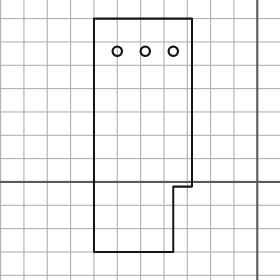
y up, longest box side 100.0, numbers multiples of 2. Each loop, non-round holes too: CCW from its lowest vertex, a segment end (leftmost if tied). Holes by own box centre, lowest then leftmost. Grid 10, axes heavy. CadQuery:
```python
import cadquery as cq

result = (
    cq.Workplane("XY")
    .moveTo(-70.0, -30.0)
    .lineTo(-36.0, -30.0)
    .lineTo(-36.0, -2.0)
    .lineTo(-28.0, -2.0)
    .lineTo(-28.0, 70.0)
    .lineTo(-70.0, 70.0)
    .close()
    .moveTo(-60.0, 56.0)
    .circle(2.0)
    .moveTo(-48.0, 56.0)
    .circle(2.0)
    .moveTo(-36.0, 56.0)
    .circle(2.0)
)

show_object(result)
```